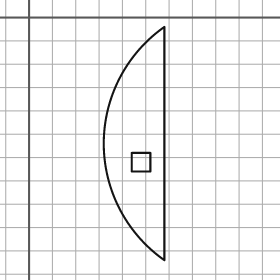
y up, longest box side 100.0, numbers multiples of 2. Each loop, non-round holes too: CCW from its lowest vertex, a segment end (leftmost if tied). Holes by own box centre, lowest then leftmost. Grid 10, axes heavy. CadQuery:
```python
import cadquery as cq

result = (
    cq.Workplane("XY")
    .moveTo(58.0, -104.0)
    .lineTo(58.0, -4.0)
    .threePointArc((32.0, -54.0), (58.0, -104.0))
    .close()
    .moveTo(44.0, -66.0)
    .lineTo(52.0, -66.0)
    .lineTo(52.0, -58.0)
    .lineTo(44.0, -58.0)
    .close()
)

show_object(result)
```